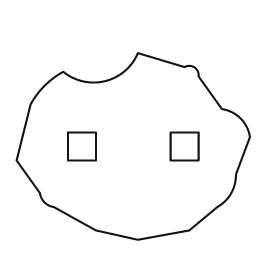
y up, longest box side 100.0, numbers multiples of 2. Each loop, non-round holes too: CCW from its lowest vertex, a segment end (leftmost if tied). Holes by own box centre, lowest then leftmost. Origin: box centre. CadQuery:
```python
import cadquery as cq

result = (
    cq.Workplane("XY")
    .moveTo(2.0, -40.0)
    .lineTo(24.0, -36.0)
    .lineTo(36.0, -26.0)
    .threePointArc((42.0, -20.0), (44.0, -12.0))
    .lineTo(50.0, 4.0)
    .threePointArc((46.0, 12.0), (38.0, 16.0))
    .lineTo(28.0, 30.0)
    .threePointArc((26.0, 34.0), (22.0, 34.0))
    .lineTo(2.0, 40.0)
    .threePointArc((-12.0, 28.0), (-30.0, 32.0))
    .threePointArc((-38.0, 26.0), (-44.0, 18.0))
    .lineTo(-50.0, -6.0)
    .lineTo(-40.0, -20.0)
    .threePointArc((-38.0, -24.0), (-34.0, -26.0))
    .lineTo(-16.0, -36.0)
    .close()
    .moveTo(-28.0, -6.0)
    .lineTo(-16.0, -6.0)
    .lineTo(-16.0, 6.0)
    .lineTo(-28.0, 6.0)
    .close()
    .moveTo(16.0, -6.0)
    .lineTo(28.0, -6.0)
    .lineTo(28.0, 6.0)
    .lineTo(16.0, 6.0)
    .close()
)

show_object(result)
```